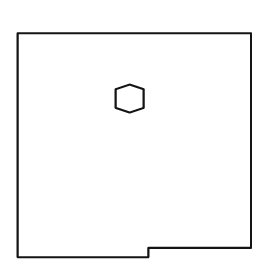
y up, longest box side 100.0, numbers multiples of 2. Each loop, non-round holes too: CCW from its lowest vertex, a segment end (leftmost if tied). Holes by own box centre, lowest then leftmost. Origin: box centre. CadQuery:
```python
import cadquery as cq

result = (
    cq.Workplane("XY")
    .moveTo(-50.0, -48.0)
    .lineTo(6.0, -48.0)
    .lineTo(6.0, -44.0)
    .lineTo(50.0, -44.0)
    .lineTo(50.0, 48.0)
    .lineTo(-50.0, 48.0)
    .close()
    .moveTo(-2.0, 14.0)
    .lineTo(4.0, 16.0)
    .lineTo(4.0, 24.0)
    .lineTo(-2.0, 26.0)
    .lineTo(-8.0, 24.0)
    .lineTo(-8.0, 16.0)
    .close()
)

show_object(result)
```